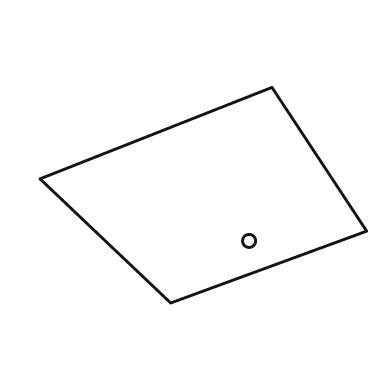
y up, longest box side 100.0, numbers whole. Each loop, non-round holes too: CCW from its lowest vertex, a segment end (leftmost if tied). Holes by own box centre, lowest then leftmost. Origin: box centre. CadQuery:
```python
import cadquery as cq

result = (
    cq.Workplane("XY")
    .moveTo(-10.0, -33.0)
    .lineTo(50.0, -11.0)
    .lineTo(21.0, 33.0)
    .lineTo(-50.0, 5.0)
    .close()
    .moveTo(14.0, -14.0)
    .circle(2.0)
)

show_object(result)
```